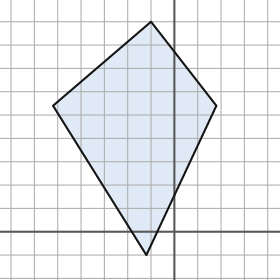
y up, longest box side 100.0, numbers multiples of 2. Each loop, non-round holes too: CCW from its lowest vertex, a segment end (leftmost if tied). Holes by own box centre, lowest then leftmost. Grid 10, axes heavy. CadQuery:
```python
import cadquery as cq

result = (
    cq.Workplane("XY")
    .moveTo(-12.0, -10.0)
    .lineTo(18.0, 54.0)
    .lineTo(-10.0, 90.0)
    .lineTo(-52.0, 54.0)
    .close()
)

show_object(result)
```